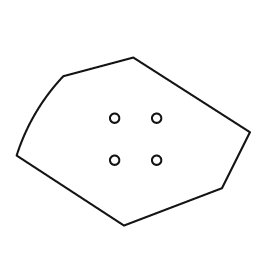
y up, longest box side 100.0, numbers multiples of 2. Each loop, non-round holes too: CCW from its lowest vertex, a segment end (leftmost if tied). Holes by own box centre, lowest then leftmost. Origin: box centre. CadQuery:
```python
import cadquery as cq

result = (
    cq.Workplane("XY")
    .moveTo(-4.0, -36.0)
    .lineTo(38.0, -20.0)
    .lineTo(50.0, 4.0)
    .lineTo(0.0, 36.0)
    .lineTo(-30.0, 28.0)
    .threePointArc((-42.0, 12.0), (-50.0, -6.0))
    .close()
    .moveTo(-8.0, -8.0)
    .circle(2.0)
    .moveTo(10.0, -8.0)
    .circle(2.0)
    .moveTo(-8.0, 10.0)
    .circle(2.0)
    .moveTo(10.0, 10.0)
    .circle(2.0)
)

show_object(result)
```